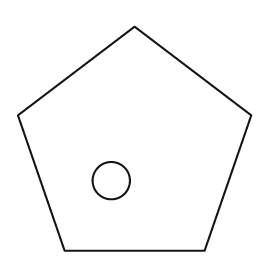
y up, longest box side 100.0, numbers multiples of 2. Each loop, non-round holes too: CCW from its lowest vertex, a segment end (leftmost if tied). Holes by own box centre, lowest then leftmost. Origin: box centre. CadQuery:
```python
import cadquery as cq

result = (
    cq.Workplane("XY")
    .moveTo(-30.0, -48.0)
    .lineTo(30.0, -48.0)
    .lineTo(50.0, 10.0)
    .lineTo(0.0, 48.0)
    .lineTo(-50.0, 10.0)
    .close()
    .moveTo(-10.0, -18.0)
    .circle(8.0)
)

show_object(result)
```